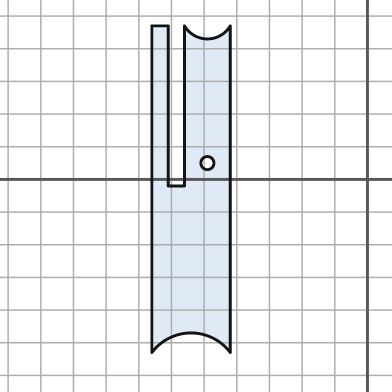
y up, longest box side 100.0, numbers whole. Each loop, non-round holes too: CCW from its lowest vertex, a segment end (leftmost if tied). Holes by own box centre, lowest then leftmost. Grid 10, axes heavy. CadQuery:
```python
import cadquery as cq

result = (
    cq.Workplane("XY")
    .moveTo(-66.0, -53.0)
    .threePointArc((-54.0, -47.0), (-42.0, -53.0))
    .lineTo(-42.0, 47.0)
    .threePointArc((-49.0, 43.0), (-56.0, 47.0))
    .lineTo(-56.0, -2.0)
    .lineTo(-61.0, -2.0)
    .lineTo(-61.0, 47.0)
    .lineTo(-66.0, 47.0)
    .close()
    .moveTo(-49.0, 5.0)
    .circle(2.0)
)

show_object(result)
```